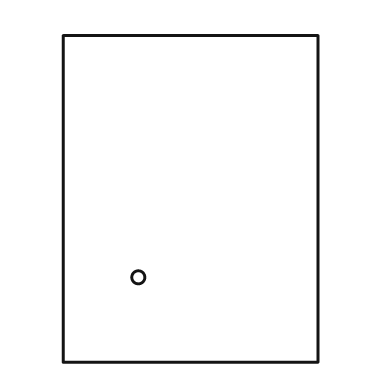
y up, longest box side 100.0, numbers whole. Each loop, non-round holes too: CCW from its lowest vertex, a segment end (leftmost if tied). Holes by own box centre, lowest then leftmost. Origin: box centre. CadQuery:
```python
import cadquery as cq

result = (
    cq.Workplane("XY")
    .moveTo(-39.0, -50.0)
    .lineTo(39.0, -50.0)
    .lineTo(39.0, 50.0)
    .lineTo(-39.0, 50.0)
    .close()
    .moveTo(-16.0, -24.0)
    .circle(2.0)
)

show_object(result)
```